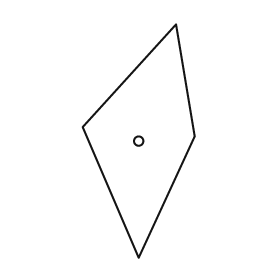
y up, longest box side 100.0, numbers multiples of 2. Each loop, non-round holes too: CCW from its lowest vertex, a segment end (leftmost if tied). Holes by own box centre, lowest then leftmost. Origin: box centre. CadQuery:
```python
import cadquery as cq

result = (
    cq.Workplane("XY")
    .moveTo(0.0, -50.0)
    .lineTo(24.0, 2.0)
    .lineTo(16.0, 50.0)
    .lineTo(-24.0, 6.0)
    .close()
    .moveTo(0.0, 0.0)
    .circle(2.0)
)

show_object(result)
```